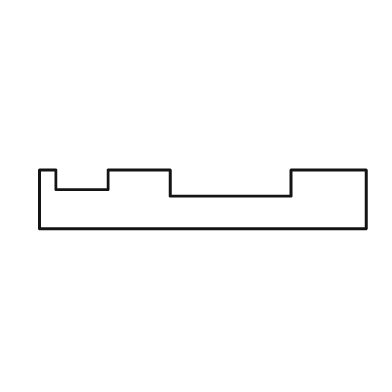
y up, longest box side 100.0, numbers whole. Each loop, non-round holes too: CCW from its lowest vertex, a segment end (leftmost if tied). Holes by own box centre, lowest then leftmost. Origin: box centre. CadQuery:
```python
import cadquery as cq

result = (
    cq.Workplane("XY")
    .moveTo(-50.0, -9.0)
    .lineTo(50.0, -9.0)
    .lineTo(50.0, 9.0)
    .lineTo(27.0, 9.0)
    .lineTo(27.0, 1.0)
    .lineTo(-10.0, 1.0)
    .lineTo(-10.0, 9.0)
    .lineTo(-29.0, 9.0)
    .lineTo(-29.0, 3.0)
    .lineTo(-45.0, 3.0)
    .lineTo(-45.0, 9.0)
    .lineTo(-50.0, 9.0)
    .close()
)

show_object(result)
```